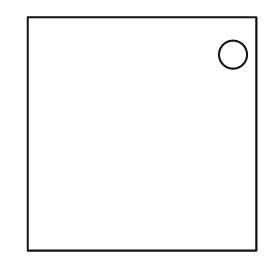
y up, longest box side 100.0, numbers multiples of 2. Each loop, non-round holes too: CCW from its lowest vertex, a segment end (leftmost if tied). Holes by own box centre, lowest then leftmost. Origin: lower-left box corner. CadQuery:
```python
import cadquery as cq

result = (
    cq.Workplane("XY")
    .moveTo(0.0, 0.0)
    .lineTo(98.0, 0.0)
    .lineTo(98.0, 100.0)
    .lineTo(0.0, 100.0)
    .close()
    .moveTo(88.0, 84.0)
    .circle(6.0)
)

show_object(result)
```